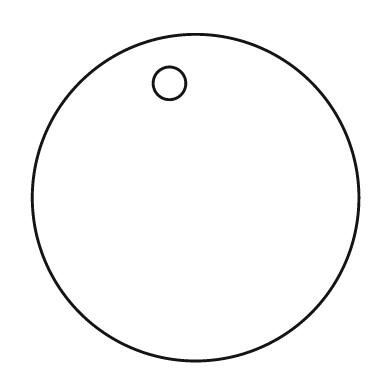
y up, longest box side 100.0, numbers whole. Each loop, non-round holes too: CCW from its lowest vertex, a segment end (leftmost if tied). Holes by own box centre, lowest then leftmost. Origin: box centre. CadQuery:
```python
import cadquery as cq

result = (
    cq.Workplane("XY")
    .moveTo(0.0, 0.0)
    .circle(50.0)
    .moveTo(-8.0, 35.0)
    .circle(5.0)
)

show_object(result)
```